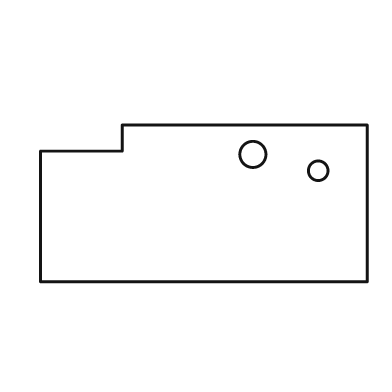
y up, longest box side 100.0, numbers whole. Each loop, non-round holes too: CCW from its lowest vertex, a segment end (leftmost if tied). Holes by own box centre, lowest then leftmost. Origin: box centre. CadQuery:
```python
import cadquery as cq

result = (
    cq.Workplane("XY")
    .moveTo(-50.0, -24.0)
    .lineTo(50.0, -24.0)
    .lineTo(50.0, 24.0)
    .lineTo(-25.0, 24.0)
    .lineTo(-25.0, 16.0)
    .lineTo(-50.0, 16.0)
    .close()
    .moveTo(35.0, 10.0)
    .circle(3.0)
    .moveTo(15.0, 15.0)
    .circle(4.0)
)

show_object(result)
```